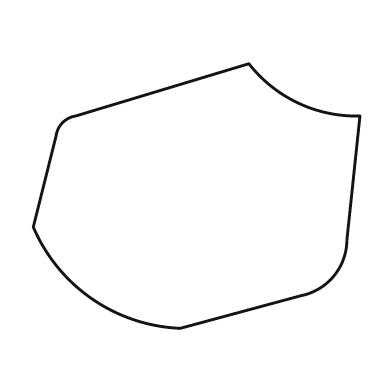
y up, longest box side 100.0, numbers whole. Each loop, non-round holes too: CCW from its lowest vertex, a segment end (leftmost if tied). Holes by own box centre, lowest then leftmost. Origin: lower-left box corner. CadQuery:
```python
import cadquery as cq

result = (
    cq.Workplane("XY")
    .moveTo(45.0, 0.0)
    .lineTo(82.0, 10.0)
    .threePointArc((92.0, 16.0), (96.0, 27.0))
    .lineTo(100.0, 65.0)
    .threePointArc((81.0, 69.0), (66.0, 81.0))
    .lineTo(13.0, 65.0)
    .threePointArc((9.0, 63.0), (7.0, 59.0))
    .lineTo(0.0, 31.0)
    .threePointArc((18.0, 9.0), (45.0, 0.0))
    .close()
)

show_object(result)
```